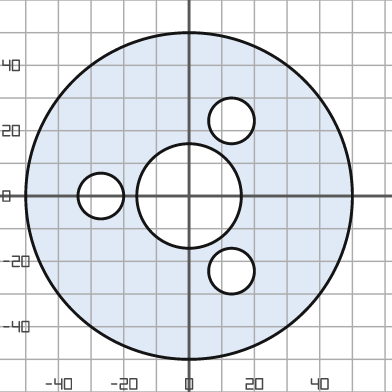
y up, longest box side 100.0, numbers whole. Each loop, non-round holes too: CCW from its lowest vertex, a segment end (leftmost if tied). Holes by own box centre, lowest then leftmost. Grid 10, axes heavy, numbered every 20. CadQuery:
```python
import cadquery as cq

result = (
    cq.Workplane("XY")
    .moveTo(0.0, 0.0)
    .circle(50.0)
    .moveTo(13.0, -23.0)
    .circle(7.0)
    .moveTo(-27.0, 0.0)
    .circle(7.0)
    .moveTo(0.0, 0.0)
    .circle(16.0)
    .moveTo(13.0, 23.0)
    .circle(7.0)
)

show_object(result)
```